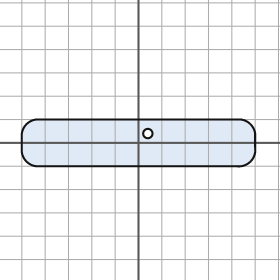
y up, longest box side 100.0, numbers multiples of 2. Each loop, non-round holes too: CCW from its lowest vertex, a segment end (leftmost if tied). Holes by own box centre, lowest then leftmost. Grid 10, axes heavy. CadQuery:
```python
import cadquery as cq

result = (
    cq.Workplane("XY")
    .moveTo(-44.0, -10.0)
    .lineTo(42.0, -10.0)
    .threePointArc((48.0, -8.0), (50.0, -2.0))
    .lineTo(50.0, 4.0)
    .threePointArc((48.0, 8.0), (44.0, 10.0))
    .lineTo(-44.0, 10.0)
    .threePointArc((-48.0, 8.0), (-50.0, 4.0))
    .lineTo(-50.0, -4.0)
    .threePointArc((-48.0, -8.0), (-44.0, -10.0))
    .close()
    .moveTo(4.0, 4.0)
    .circle(2.0)
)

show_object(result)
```